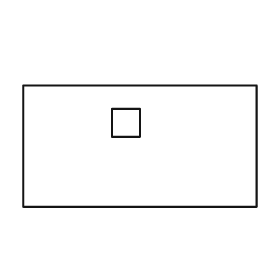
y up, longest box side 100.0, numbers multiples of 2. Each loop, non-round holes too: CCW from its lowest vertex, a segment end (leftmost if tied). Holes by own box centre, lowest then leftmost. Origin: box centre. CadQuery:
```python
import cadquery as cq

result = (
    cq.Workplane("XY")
    .moveTo(-50.0, -26.0)
    .lineTo(50.0, -26.0)
    .lineTo(50.0, 26.0)
    .lineTo(-50.0, 26.0)
    .close()
    .moveTo(-12.0, 4.0)
    .lineTo(0.0, 4.0)
    .lineTo(0.0, 16.0)
    .lineTo(-12.0, 16.0)
    .close()
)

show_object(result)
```